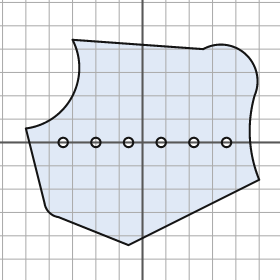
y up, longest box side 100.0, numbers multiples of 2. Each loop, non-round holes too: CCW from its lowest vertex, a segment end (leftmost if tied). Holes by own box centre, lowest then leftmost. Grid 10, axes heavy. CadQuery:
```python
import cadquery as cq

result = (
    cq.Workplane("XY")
    .moveTo(-6.0, -44.0)
    .lineTo(50.0, -16.0)
    .threePointArc((46.0, 2.0), (48.0, 20.0))
    .threePointArc((44.0, 38.0), (26.0, 40.0))
    .lineTo(-30.0, 44.0)
    .threePointArc((-30.0, 20.0), (-50.0, 6.0))
    .lineTo(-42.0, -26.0)
    .threePointArc((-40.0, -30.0), (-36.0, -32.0))
    .close()
    .moveTo(-34.0, 0.0)
    .circle(2.0)
    .moveTo(-20.0, 0.0)
    .circle(2.0)
    .moveTo(-6.0, 0.0)
    .circle(2.0)
    .moveTo(8.0, 0.0)
    .circle(2.0)
    .moveTo(22.0, 0.0)
    .circle(2.0)
    .moveTo(36.0, 0.0)
    .circle(2.0)
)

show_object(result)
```